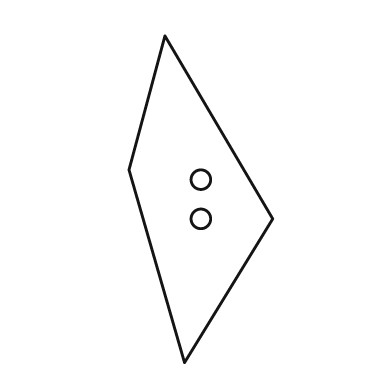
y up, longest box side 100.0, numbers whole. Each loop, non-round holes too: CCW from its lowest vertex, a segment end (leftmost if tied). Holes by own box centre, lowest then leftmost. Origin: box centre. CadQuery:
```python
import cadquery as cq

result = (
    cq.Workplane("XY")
    .moveTo(-5.0, -50.0)
    .lineTo(22.0, -6.0)
    .lineTo(-11.0, 50.0)
    .lineTo(-22.0, 9.0)
    .close()
    .moveTo(0.0, -6.0)
    .circle(3.0)
    .moveTo(0.0, 6.0)
    .circle(3.0)
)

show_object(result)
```